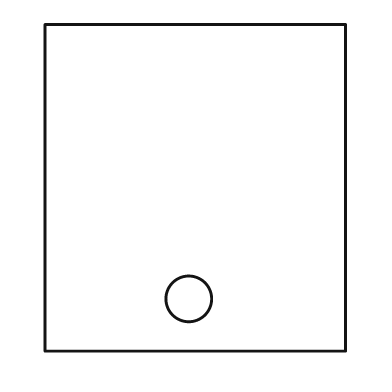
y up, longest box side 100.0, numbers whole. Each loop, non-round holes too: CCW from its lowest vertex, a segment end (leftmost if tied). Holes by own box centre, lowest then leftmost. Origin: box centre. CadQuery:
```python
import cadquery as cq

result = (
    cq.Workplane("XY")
    .moveTo(-46.0, -50.0)
    .lineTo(46.0, -50.0)
    .lineTo(46.0, 50.0)
    .lineTo(-46.0, 50.0)
    .close()
    .moveTo(-2.0, -34.0)
    .circle(7.0)
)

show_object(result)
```